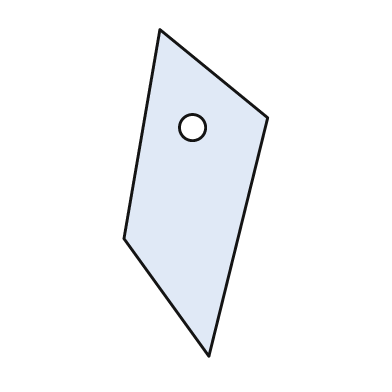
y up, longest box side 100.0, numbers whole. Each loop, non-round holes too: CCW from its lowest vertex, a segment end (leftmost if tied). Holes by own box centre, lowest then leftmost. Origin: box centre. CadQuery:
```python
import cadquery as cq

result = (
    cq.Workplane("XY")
    .moveTo(4.0, -50.0)
    .lineTo(22.0, 23.0)
    .lineTo(-11.0, 50.0)
    .lineTo(-22.0, -14.0)
    .close()
    .moveTo(-1.0, 20.0)
    .circle(4.0)
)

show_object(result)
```